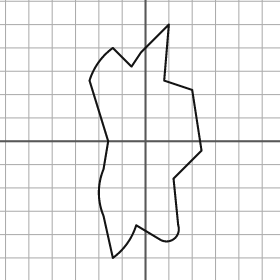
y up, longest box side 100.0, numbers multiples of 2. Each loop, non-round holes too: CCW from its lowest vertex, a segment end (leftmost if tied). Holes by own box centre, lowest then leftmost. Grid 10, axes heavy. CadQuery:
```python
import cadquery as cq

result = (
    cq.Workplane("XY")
    .moveTo(-14.0, -50.0)
    .threePointArc((-8.0, -44.0), (-4.0, -36.0))
    .lineTo(6.0, -42.0)
    .threePointArc((12.0, -42.0), (14.0, -36.0))
    .lineTo(12.0, -16.0)
    .lineTo(24.0, -4.0)
    .lineTo(20.0, 22.0)
    .lineTo(8.0, 26.0)
    .lineTo(10.0, 50.0)
    .lineTo(-2.0, 38.0)
    .lineTo(-6.0, 32.0)
    .lineTo(-14.0, 40.0)
    .threePointArc((-20.0, 34.0), (-24.0, 26.0))
    .lineTo(-16.0, 0.0)
    .lineTo(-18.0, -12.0)
    .threePointArc((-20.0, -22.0), (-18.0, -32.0))
    .close()
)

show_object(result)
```